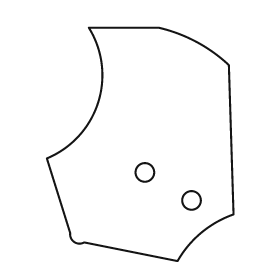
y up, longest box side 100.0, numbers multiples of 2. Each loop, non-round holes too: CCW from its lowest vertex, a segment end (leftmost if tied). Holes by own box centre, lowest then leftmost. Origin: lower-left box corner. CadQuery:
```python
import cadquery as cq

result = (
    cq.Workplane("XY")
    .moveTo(56.0, 0.0)
    .threePointArc((66.0, 12.0), (80.0, 20.0))
    .lineTo(78.0, 84.0)
    .threePointArc((64.0, 94.0), (48.0, 100.0))
    .lineTo(18.0, 100.0)
    .threePointArc((22.0, 68.0), (0.0, 44.0))
    .lineTo(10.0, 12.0)
    .threePointArc((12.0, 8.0), (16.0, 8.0))
    .close()
    .moveTo(62.0, 26.0)
    .circle(4.0)
    .moveTo(42.0, 38.0)
    .circle(4.0)
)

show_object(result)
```